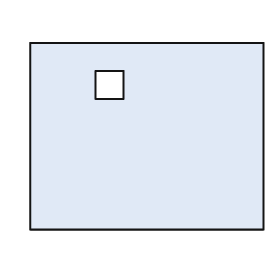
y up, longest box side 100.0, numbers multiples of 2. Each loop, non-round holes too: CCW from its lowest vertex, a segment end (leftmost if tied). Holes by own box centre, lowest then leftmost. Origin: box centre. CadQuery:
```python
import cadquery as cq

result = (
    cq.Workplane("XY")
    .moveTo(-50.0, -40.0)
    .lineTo(50.0, -40.0)
    .lineTo(50.0, 40.0)
    .lineTo(-50.0, 40.0)
    .close()
    .moveTo(-22.0, 16.0)
    .lineTo(-10.0, 16.0)
    .lineTo(-10.0, 28.0)
    .lineTo(-22.0, 28.0)
    .close()
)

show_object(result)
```